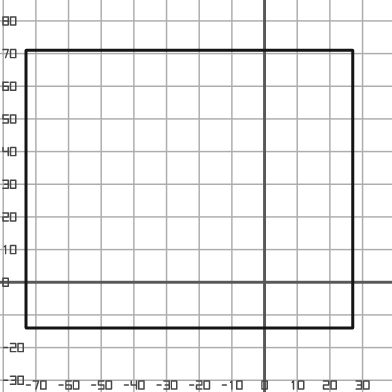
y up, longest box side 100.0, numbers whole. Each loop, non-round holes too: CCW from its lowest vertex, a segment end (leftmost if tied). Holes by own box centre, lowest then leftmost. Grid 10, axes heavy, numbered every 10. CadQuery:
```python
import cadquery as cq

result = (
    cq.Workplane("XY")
    .moveTo(-73.0, -14.0)
    .lineTo(27.0, -14.0)
    .lineTo(27.0, 71.0)
    .lineTo(-73.0, 71.0)
    .close()
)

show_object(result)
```